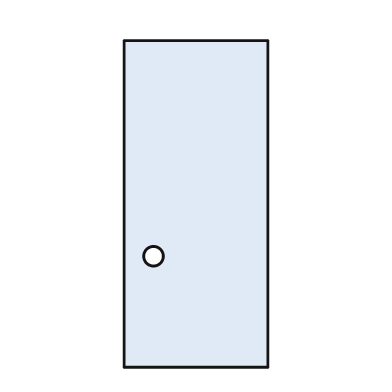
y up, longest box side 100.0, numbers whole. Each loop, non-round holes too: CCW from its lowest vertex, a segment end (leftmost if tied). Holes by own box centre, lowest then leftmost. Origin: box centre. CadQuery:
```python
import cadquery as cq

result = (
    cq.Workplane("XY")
    .moveTo(-22.0, -50.0)
    .lineTo(22.0, -50.0)
    .lineTo(22.0, 50.0)
    .lineTo(-22.0, 50.0)
    .close()
    .moveTo(-13.0, -16.0)
    .circle(3.0)
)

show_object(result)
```